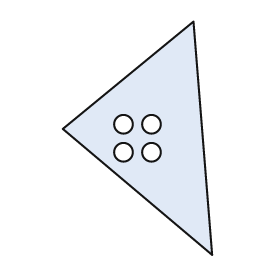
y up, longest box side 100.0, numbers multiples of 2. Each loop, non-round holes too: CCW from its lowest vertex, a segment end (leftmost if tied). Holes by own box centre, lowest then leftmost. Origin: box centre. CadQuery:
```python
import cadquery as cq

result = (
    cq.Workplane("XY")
    .moveTo(32.0, -50.0)
    .lineTo(24.0, 50.0)
    .lineTo(-32.0, 4.0)
    .close()
    .moveTo(-6.0, -6.0)
    .circle(4.0)
    .moveTo(6.0, -6.0)
    .circle(4.0)
    .moveTo(-6.0, 6.0)
    .circle(4.0)
    .moveTo(6.0, 6.0)
    .circle(4.0)
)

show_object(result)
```